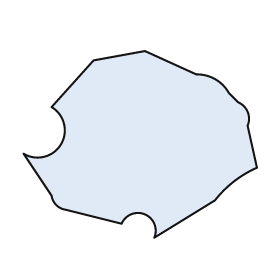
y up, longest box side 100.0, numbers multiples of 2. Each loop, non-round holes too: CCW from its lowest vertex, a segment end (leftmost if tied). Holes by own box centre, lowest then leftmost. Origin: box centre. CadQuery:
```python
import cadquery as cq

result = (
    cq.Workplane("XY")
    .moveTo(6.0, -40.0)
    .lineTo(32.0, -24.0)
    .threePointArc((40.0, -16.0), (50.0, -10.0))
    .lineTo(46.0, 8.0)
    .threePointArc((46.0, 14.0), (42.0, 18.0))
    .lineTo(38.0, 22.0)
    .threePointArc((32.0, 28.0), (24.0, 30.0))
    .lineTo(2.0, 40.0)
    .lineTo(-20.0, 36.0)
    .lineTo(-38.0, 16.0)
    .threePointArc((-34.0, 0.0), (-50.0, -4.0))
    .lineTo(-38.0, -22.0)
    .threePointArc((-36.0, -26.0), (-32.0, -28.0))
    .lineTo(-8.0, -34.0)
    .threePointArc((2.0, -30.0), (6.0, -40.0))
    .close()
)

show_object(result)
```